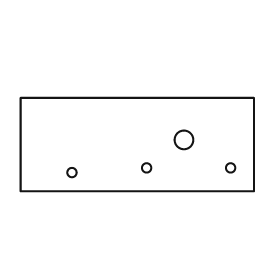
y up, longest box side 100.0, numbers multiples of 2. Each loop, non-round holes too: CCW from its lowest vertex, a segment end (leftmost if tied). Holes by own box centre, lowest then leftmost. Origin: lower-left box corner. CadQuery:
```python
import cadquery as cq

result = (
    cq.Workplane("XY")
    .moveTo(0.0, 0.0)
    .lineTo(100.0, 0.0)
    .lineTo(100.0, 40.0)
    .lineTo(0.0, 40.0)
    .close()
    .moveTo(22.0, 8.0)
    .circle(2.0)
    .moveTo(54.0, 10.0)
    .circle(2.0)
    .moveTo(90.0, 10.0)
    .circle(2.0)
    .moveTo(70.0, 22.0)
    .circle(4.0)
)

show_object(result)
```